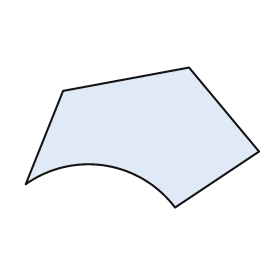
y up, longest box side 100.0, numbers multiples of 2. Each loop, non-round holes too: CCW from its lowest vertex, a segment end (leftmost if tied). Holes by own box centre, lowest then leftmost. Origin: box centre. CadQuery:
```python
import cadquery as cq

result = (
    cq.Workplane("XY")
    .moveTo(14.0, -30.0)
    .lineTo(50.0, -6.0)
    .lineTo(20.0, 30.0)
    .lineTo(-34.0, 20.0)
    .lineTo(-50.0, -20.0)
    .threePointArc((-16.0, -12.0), (14.0, -30.0))
    .close()
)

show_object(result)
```